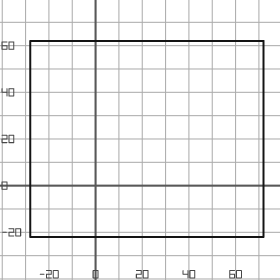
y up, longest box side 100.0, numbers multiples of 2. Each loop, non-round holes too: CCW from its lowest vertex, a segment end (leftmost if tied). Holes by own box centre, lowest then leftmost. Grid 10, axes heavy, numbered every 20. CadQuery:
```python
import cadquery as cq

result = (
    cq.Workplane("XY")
    .moveTo(-28.0, -22.0)
    .lineTo(72.0, -22.0)
    .lineTo(72.0, 62.0)
    .lineTo(-28.0, 62.0)
    .close()
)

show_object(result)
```